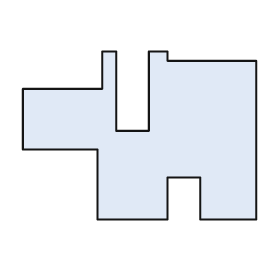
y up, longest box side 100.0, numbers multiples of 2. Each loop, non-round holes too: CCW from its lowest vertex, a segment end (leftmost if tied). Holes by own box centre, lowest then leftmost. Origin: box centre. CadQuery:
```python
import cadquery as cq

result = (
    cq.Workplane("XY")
    .moveTo(-18.0, -36.0)
    .lineTo(12.0, -36.0)
    .lineTo(12.0, -18.0)
    .lineTo(26.0, -18.0)
    .lineTo(26.0, -36.0)
    .lineTo(50.0, -36.0)
    .lineTo(50.0, 32.0)
    .lineTo(12.0, 32.0)
    .lineTo(12.0, 36.0)
    .lineTo(4.0, 36.0)
    .lineTo(4.0, 2.0)
    .lineTo(-10.0, 2.0)
    .lineTo(-10.0, 36.0)
    .lineTo(-16.0, 36.0)
    .lineTo(-16.0, 20.0)
    .lineTo(-50.0, 20.0)
    .lineTo(-50.0, -6.0)
    .lineTo(-18.0, -6.0)
    .close()
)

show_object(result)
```